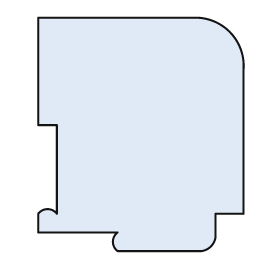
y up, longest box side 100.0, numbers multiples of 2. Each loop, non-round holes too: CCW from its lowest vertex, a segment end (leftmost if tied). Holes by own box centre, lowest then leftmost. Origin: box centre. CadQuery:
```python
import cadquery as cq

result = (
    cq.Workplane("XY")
    .moveTo(-10.0, -50.0)
    .lineTo(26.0, -50.0)
    .threePointArc((30.0, -48.0), (32.0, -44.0))
    .lineTo(32.0, -34.0)
    .lineTo(44.0, -34.0)
    .lineTo(44.0, 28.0)
    .threePointArc((38.0, 44.0), (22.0, 50.0))
    .lineTo(-44.0, 50.0)
    .lineTo(-44.0, 4.0)
    .lineTo(-36.0, 4.0)
    .lineTo(-36.0, -34.0)
    .threePointArc((-40.0, -32.0), (-44.0, -34.0))
    .lineTo(-44.0, -42.0)
    .lineTo(-10.0, -42.0)
    .threePointArc((-12.0, -46.0), (-10.0, -50.0))
    .close()
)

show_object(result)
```